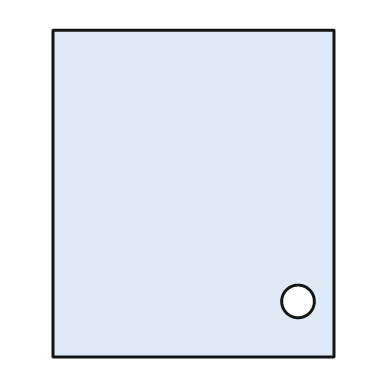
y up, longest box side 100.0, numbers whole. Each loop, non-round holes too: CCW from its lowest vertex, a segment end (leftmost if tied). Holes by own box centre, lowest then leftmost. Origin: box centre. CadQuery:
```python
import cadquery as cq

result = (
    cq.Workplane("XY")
    .moveTo(-43.0, -50.0)
    .lineTo(43.0, -50.0)
    .lineTo(43.0, 50.0)
    .lineTo(-43.0, 50.0)
    .close()
    .moveTo(32.0, -33.0)
    .circle(5.0)
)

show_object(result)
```